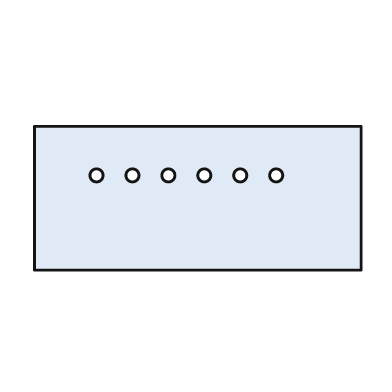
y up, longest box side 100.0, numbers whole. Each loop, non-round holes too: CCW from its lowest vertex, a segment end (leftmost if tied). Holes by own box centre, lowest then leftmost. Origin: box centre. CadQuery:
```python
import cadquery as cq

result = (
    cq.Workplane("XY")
    .moveTo(-50.0, -22.0)
    .lineTo(50.0, -22.0)
    .lineTo(50.0, 22.0)
    .lineTo(-50.0, 22.0)
    .close()
    .moveTo(-31.0, 7.0)
    .circle(2.0)
    .moveTo(-20.0, 7.0)
    .circle(2.0)
    .moveTo(-9.0, 7.0)
    .circle(2.0)
    .moveTo(2.0, 7.0)
    .circle(2.0)
    .moveTo(13.0, 7.0)
    .circle(2.0)
    .moveTo(24.0, 7.0)
    .circle(2.0)
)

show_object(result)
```